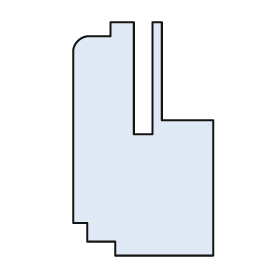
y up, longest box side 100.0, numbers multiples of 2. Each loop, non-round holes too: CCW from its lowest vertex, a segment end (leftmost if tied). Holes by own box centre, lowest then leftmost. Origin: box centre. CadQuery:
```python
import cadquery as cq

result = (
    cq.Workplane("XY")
    .moveTo(-12.0, -50.0)
    .lineTo(30.0, -50.0)
    .lineTo(30.0, 8.0)
    .lineTo(8.0, 8.0)
    .lineTo(8.0, 50.0)
    .lineTo(4.0, 50.0)
    .lineTo(4.0, 2.0)
    .lineTo(-4.0, 2.0)
    .lineTo(-4.0, 50.0)
    .lineTo(-14.0, 50.0)
    .lineTo(-14.0, 44.0)
    .lineTo(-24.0, 44.0)
    .threePointArc((-28.0, 42.0), (-30.0, 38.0))
    .lineTo(-30.0, -36.0)
    .lineTo(-24.0, -36.0)
    .lineTo(-24.0, -44.0)
    .lineTo(-12.0, -44.0)
    .close()
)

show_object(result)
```